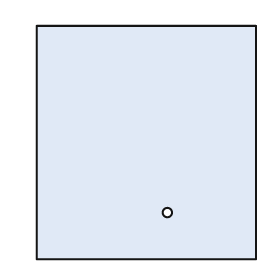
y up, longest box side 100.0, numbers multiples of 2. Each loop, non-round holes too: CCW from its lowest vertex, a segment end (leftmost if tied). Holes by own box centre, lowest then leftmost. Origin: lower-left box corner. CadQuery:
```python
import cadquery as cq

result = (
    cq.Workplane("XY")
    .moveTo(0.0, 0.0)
    .lineTo(94.0, 0.0)
    .lineTo(94.0, 100.0)
    .lineTo(0.0, 100.0)
    .close()
    .moveTo(56.0, 20.0)
    .circle(2.0)
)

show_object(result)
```